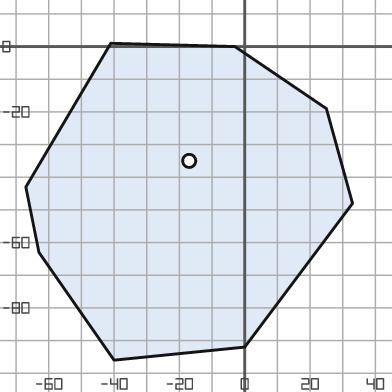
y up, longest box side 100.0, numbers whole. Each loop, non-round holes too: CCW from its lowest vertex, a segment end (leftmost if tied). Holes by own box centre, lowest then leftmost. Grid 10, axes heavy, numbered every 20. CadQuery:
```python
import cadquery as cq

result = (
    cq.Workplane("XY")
    .moveTo(-40.0, -96.0)
    .lineTo(0.0, -92.0)
    .lineTo(33.0, -48.0)
    .lineTo(25.0, -19.0)
    .lineTo(-3.0, 0.0)
    .lineTo(-41.0, 1.0)
    .lineTo(-67.0, -43.0)
    .lineTo(-63.0, -63.0)
    .close()
    .moveTo(-17.0, -35.0)
    .circle(2.0)
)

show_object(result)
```